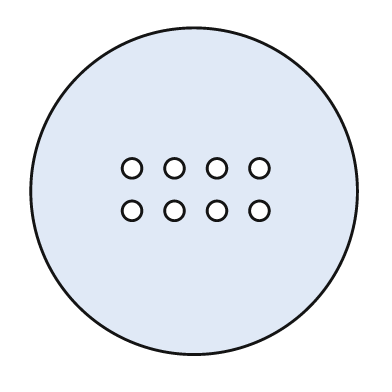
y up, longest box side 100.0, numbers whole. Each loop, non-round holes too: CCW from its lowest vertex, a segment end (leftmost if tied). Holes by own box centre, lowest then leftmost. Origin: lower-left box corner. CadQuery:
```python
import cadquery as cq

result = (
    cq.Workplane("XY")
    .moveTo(50.0, 50.0)
    .circle(50.0)
    .moveTo(31.0, 44.0)
    .circle(3.0)
    .moveTo(44.0, 44.0)
    .circle(3.0)
    .moveTo(57.0, 44.0)
    .circle(3.0)
    .moveTo(70.0, 44.0)
    .circle(3.0)
    .moveTo(31.0, 57.0)
    .circle(3.0)
    .moveTo(44.0, 57.0)
    .circle(3.0)
    .moveTo(57.0, 57.0)
    .circle(3.0)
    .moveTo(70.0, 57.0)
    .circle(3.0)
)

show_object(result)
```